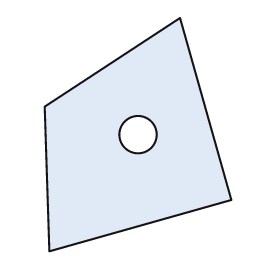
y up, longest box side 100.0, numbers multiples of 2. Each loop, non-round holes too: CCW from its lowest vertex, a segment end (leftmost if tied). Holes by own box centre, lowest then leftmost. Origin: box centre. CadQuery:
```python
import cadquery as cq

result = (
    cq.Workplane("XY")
    .moveTo(-38.0, -50.0)
    .lineTo(40.0, -28.0)
    .lineTo(18.0, 50.0)
    .lineTo(-40.0, 12.0)
    .close()
    .moveTo(0.0, 0.0)
    .circle(8.0)
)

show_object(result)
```